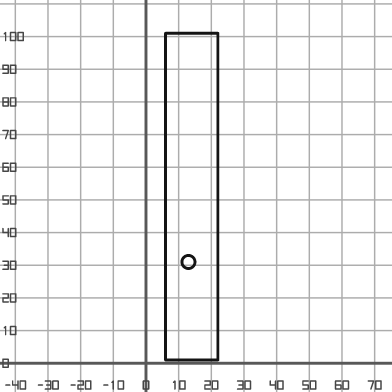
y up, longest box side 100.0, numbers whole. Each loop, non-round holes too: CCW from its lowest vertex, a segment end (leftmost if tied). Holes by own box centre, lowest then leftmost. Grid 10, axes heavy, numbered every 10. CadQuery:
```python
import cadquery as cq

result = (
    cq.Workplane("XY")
    .moveTo(6.0, 1.0)
    .lineTo(22.0, 1.0)
    .lineTo(22.0, 101.0)
    .lineTo(6.0, 101.0)
    .close()
    .moveTo(13.0, 31.0)
    .circle(2.0)
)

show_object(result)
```